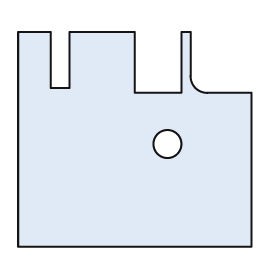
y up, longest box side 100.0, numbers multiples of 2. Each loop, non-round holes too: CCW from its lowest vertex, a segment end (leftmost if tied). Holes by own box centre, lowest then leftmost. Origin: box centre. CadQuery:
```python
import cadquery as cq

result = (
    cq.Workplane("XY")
    .moveTo(-50.0, -46.0)
    .lineTo(50.0, -46.0)
    .lineTo(50.0, 20.0)
    .lineTo(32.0, 20.0)
    .threePointArc((26.0, 22.0), (24.0, 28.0))
    .lineTo(24.0, 46.0)
    .lineTo(20.0, 46.0)
    .lineTo(20.0, 20.0)
    .lineTo(0.0, 20.0)
    .lineTo(0.0, 46.0)
    .lineTo(-28.0, 46.0)
    .lineTo(-28.0, 22.0)
    .lineTo(-36.0, 22.0)
    .lineTo(-36.0, 46.0)
    .lineTo(-50.0, 46.0)
    .close()
    .moveTo(14.0, -2.0)
    .circle(6.0)
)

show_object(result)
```